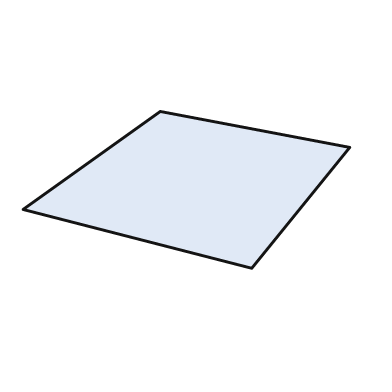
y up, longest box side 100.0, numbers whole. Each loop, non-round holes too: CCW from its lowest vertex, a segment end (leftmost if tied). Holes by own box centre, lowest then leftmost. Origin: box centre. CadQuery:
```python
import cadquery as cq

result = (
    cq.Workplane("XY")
    .moveTo(20.0, -24.0)
    .lineTo(50.0, 13.0)
    .lineTo(-8.0, 24.0)
    .lineTo(-50.0, -6.0)
    .close()
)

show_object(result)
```